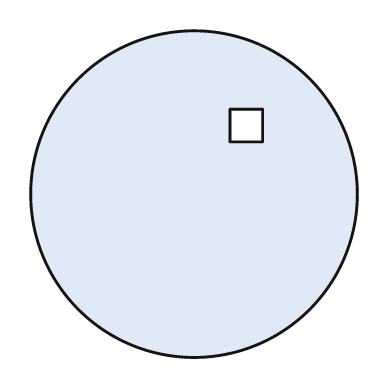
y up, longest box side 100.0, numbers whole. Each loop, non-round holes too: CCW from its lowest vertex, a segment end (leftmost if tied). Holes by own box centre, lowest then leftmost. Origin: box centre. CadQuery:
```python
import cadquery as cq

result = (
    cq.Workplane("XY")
    .moveTo(0.0, 0.0)
    .circle(50.0)
    .moveTo(11.0, 16.0)
    .lineTo(21.0, 16.0)
    .lineTo(21.0, 26.0)
    .lineTo(11.0, 26.0)
    .close()
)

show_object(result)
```